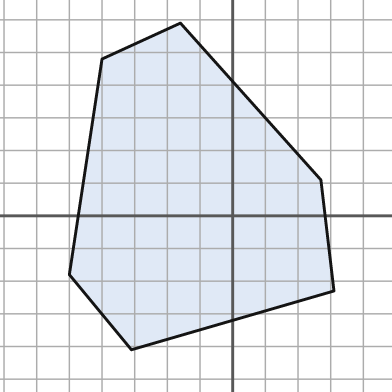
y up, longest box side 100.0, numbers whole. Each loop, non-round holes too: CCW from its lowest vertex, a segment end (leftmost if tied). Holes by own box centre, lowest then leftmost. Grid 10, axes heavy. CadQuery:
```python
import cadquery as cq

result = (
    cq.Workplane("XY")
    .moveTo(-31.0, -41.0)
    .lineTo(31.0, -23.0)
    .lineTo(27.0, 11.0)
    .lineTo(-16.0, 59.0)
    .lineTo(-40.0, 48.0)
    .lineTo(-50.0, -18.0)
    .close()
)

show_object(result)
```